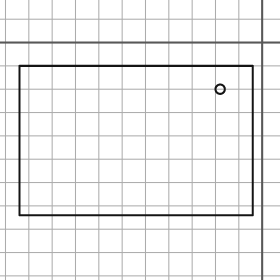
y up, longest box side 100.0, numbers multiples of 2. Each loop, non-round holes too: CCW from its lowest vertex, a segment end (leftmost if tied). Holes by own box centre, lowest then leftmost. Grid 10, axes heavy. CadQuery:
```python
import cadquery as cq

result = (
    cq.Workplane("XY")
    .moveTo(-104.0, -74.0)
    .lineTo(-4.0, -74.0)
    .lineTo(-4.0, -10.0)
    .lineTo(-104.0, -10.0)
    .close()
    .moveTo(-18.0, -20.0)
    .circle(2.0)
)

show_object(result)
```